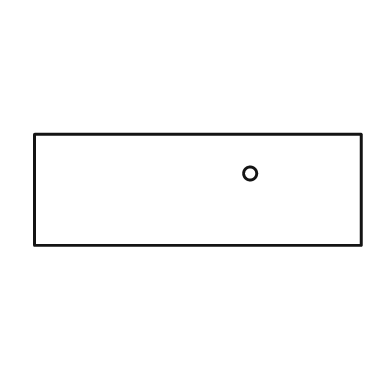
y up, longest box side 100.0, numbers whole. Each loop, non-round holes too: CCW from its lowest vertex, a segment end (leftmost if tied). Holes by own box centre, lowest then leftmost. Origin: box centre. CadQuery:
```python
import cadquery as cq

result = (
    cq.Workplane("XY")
    .moveTo(-50.0, -17.0)
    .lineTo(50.0, -17.0)
    .lineTo(50.0, 17.0)
    .lineTo(-50.0, 17.0)
    .close()
    .moveTo(16.0, 5.0)
    .circle(2.0)
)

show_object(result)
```